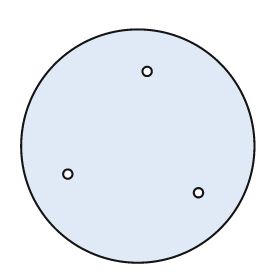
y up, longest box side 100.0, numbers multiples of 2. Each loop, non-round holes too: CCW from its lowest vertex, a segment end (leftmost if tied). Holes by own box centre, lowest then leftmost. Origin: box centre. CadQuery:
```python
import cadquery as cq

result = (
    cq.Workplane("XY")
    .moveTo(0.0, 0.0)
    .circle(50.0)
    .moveTo(26.0, -20.0)
    .circle(2.0)
    .moveTo(-30.0, -12.0)
    .circle(2.0)
    .moveTo(4.0, 32.0)
    .circle(2.0)
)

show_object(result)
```